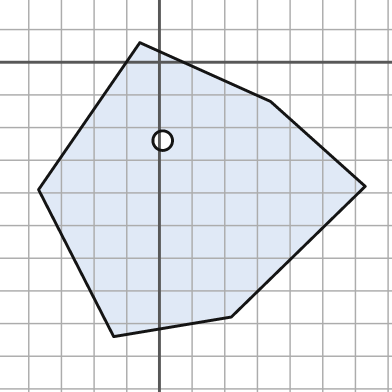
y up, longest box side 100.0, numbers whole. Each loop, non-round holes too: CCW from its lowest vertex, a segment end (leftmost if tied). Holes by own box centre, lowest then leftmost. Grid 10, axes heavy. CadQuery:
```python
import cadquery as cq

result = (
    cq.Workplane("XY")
    .moveTo(-14.0, -84.0)
    .lineTo(22.0, -78.0)
    .lineTo(63.0, -38.0)
    .lineTo(34.0, -12.0)
    .lineTo(-6.0, 6.0)
    .lineTo(-37.0, -39.0)
    .close()
    .moveTo(1.0, -24.0)
    .circle(3.0)
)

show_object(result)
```